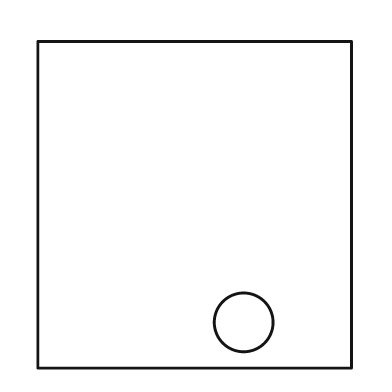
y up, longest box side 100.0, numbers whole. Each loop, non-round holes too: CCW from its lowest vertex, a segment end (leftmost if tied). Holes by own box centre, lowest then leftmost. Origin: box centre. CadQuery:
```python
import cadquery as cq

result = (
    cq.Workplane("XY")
    .moveTo(-48.0, -50.0)
    .lineTo(48.0, -50.0)
    .lineTo(48.0, 50.0)
    .lineTo(-48.0, 50.0)
    .close()
    .moveTo(15.0, -36.0)
    .circle(9.0)
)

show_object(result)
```